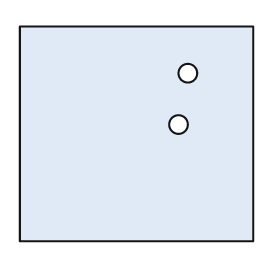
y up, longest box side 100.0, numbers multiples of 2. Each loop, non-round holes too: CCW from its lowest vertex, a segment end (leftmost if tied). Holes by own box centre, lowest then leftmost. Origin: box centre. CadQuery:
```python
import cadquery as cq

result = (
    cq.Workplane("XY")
    .moveTo(-50.0, -46.0)
    .lineTo(50.0, -46.0)
    .lineTo(50.0, 46.0)
    .lineTo(-50.0, 46.0)
    .close()
    .moveTo(18.0, 4.0)
    .circle(4.0)
    .moveTo(22.0, 26.0)
    .circle(4.0)
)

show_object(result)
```